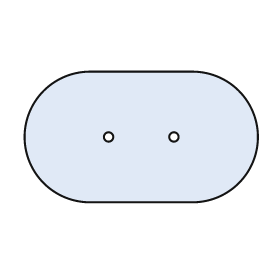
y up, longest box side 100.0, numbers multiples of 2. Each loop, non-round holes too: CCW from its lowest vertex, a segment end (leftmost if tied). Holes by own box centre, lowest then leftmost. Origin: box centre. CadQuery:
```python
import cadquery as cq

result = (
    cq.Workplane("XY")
    .moveTo(-22.0, -28.0)
    .lineTo(22.0, -28.0)
    .threePointArc((50.0, 0.0), (22.0, 28.0))
    .lineTo(-22.0, 28.0)
    .threePointArc((-50.0, 0.0), (-22.0, -28.0))
    .close()
    .moveTo(-14.0, 0.0)
    .circle(2.0)
    .moveTo(14.0, 0.0)
    .circle(2.0)
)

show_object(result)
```